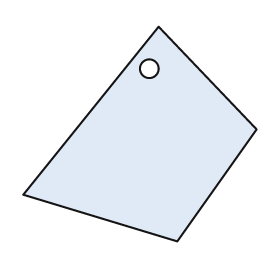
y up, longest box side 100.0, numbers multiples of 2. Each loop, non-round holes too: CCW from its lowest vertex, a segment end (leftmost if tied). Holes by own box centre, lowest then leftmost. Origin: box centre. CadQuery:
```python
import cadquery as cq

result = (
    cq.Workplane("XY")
    .moveTo(16.0, -46.0)
    .lineTo(50.0, 2.0)
    .lineTo(8.0, 46.0)
    .lineTo(-50.0, -26.0)
    .close()
    .moveTo(4.0, 28.0)
    .circle(4.0)
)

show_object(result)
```